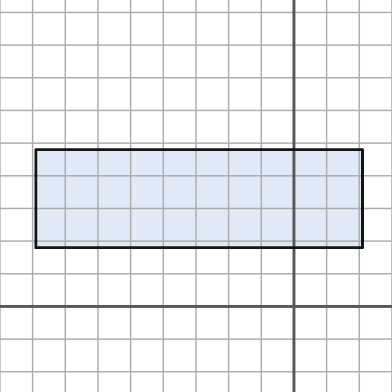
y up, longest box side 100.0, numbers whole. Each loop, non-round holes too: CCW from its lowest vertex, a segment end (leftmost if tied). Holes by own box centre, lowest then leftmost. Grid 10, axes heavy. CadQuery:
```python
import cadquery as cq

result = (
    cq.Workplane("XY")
    .moveTo(-79.0, 18.0)
    .lineTo(21.0, 18.0)
    .lineTo(21.0, 48.0)
    .lineTo(-79.0, 48.0)
    .close()
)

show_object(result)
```